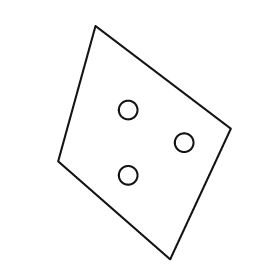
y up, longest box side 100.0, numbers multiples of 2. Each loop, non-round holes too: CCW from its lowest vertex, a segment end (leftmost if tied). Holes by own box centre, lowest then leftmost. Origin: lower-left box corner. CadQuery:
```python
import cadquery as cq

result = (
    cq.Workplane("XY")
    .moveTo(48.0, 0.0)
    .lineTo(74.0, 56.0)
    .lineTo(16.0, 100.0)
    .lineTo(0.0, 42.0)
    .close()
    .moveTo(30.0, 36.0)
    .circle(4.0)
    .moveTo(54.0, 50.0)
    .circle(4.0)
    .moveTo(30.0, 64.0)
    .circle(4.0)
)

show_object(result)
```